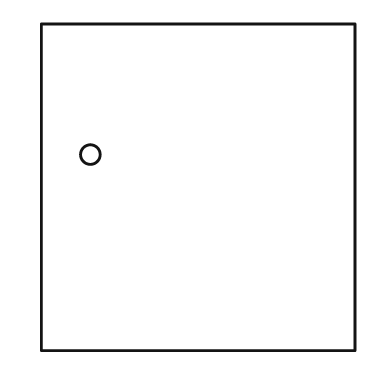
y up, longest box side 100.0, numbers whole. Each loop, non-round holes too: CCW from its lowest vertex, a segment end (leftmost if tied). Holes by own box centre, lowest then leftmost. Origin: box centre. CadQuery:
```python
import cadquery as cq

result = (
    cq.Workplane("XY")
    .moveTo(-48.0, -50.0)
    .lineTo(48.0, -50.0)
    .lineTo(48.0, 50.0)
    .lineTo(-48.0, 50.0)
    .close()
    .moveTo(-33.0, 10.0)
    .circle(3.0)
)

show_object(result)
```